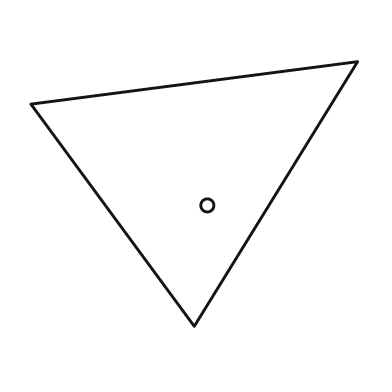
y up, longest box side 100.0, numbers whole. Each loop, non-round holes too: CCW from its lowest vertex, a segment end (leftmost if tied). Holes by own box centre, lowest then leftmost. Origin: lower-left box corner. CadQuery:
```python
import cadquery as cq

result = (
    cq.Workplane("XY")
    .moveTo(50.0, 0.0)
    .lineTo(100.0, 81.0)
    .lineTo(0.0, 68.0)
    .close()
    .moveTo(54.0, 37.0)
    .circle(2.0)
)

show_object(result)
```